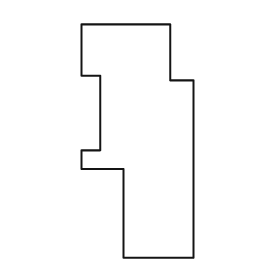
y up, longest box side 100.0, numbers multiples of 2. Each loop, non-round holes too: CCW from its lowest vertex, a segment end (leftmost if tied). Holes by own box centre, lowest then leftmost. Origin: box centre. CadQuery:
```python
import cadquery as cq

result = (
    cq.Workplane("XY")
    .moveTo(-6.0, -50.0)
    .lineTo(24.0, -50.0)
    .lineTo(24.0, 26.0)
    .lineTo(14.0, 26.0)
    .lineTo(14.0, 50.0)
    .lineTo(-24.0, 50.0)
    .lineTo(-24.0, 28.0)
    .lineTo(-16.0, 28.0)
    .lineTo(-16.0, -4.0)
    .lineTo(-24.0, -4.0)
    .lineTo(-24.0, -12.0)
    .lineTo(-6.0, -12.0)
    .close()
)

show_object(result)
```